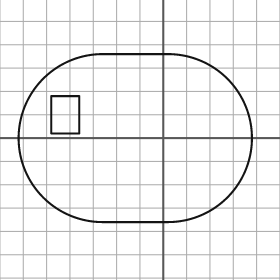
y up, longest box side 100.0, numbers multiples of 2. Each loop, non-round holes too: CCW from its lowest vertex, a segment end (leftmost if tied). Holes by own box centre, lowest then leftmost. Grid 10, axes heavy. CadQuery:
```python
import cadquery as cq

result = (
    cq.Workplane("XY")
    .moveTo(-26.0, -36.0)
    .lineTo(2.0, -36.0)
    .threePointArc((38.0, 0.0), (2.0, 36.0))
    .lineTo(-26.0, 36.0)
    .threePointArc((-62.0, 0.0), (-26.0, -36.0))
    .close()
    .moveTo(-48.0, 2.0)
    .lineTo(-36.0, 2.0)
    .lineTo(-36.0, 18.0)
    .lineTo(-48.0, 18.0)
    .close()
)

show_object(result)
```